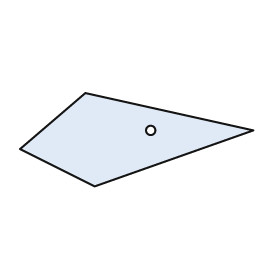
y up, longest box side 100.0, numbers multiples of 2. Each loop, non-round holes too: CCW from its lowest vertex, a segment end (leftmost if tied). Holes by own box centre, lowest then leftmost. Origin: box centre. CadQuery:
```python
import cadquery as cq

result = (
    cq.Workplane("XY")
    .moveTo(-18.0, -20.0)
    .lineTo(50.0, 4.0)
    .lineTo(-22.0, 20.0)
    .lineTo(-50.0, -4.0)
    .close()
    .moveTo(6.0, 4.0)
    .circle(2.0)
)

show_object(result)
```